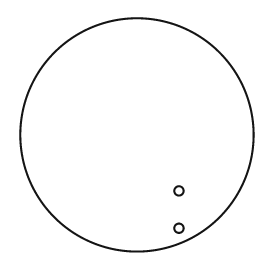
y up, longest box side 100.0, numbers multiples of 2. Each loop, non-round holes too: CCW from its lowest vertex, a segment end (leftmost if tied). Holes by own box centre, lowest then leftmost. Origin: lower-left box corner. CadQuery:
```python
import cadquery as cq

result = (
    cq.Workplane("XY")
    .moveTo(50.0, 50.0)
    .circle(50.0)
    .moveTo(68.0, 10.0)
    .circle(2.0)
    .moveTo(68.0, 26.0)
    .circle(2.0)
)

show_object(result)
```